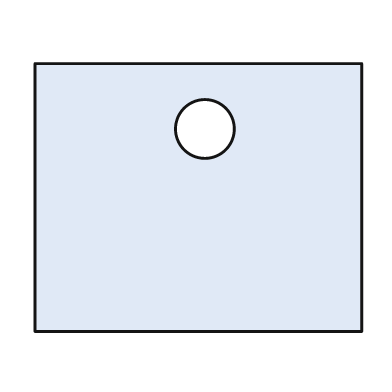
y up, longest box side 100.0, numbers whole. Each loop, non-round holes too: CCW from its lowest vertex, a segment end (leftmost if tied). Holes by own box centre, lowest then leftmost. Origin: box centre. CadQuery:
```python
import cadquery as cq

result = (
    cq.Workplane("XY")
    .moveTo(-50.0, -41.0)
    .lineTo(50.0, -41.0)
    .lineTo(50.0, 41.0)
    .lineTo(-50.0, 41.0)
    .close()
    .moveTo(2.0, 21.0)
    .circle(9.0)
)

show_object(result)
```